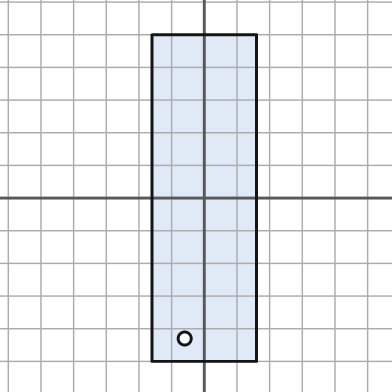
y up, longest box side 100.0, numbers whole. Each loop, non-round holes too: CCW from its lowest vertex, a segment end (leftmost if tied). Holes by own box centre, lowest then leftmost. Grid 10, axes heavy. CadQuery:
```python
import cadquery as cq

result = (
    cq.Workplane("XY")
    .moveTo(-16.0, -50.0)
    .lineTo(16.0, -50.0)
    .lineTo(16.0, 50.0)
    .lineTo(-16.0, 50.0)
    .close()
    .moveTo(-6.0, -43.0)
    .circle(2.0)
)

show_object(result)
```